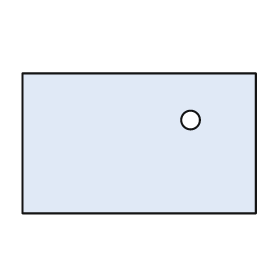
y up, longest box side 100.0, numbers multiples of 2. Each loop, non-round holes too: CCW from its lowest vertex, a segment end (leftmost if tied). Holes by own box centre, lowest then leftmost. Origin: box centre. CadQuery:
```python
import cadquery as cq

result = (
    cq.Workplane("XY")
    .moveTo(-50.0, -30.0)
    .lineTo(50.0, -30.0)
    .lineTo(50.0, 30.0)
    .lineTo(-50.0, 30.0)
    .close()
    .moveTo(22.0, 10.0)
    .circle(4.0)
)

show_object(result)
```